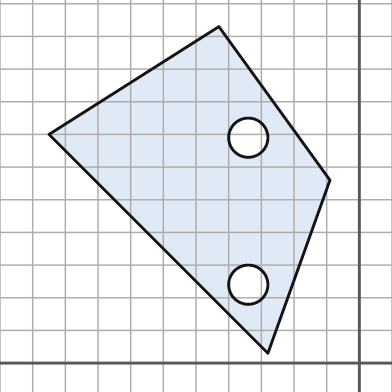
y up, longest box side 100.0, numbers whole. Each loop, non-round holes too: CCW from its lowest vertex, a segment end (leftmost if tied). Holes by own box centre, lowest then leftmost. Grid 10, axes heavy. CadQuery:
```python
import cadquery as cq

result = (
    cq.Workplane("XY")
    .moveTo(-28.0, 3.0)
    .lineTo(-9.0, 56.0)
    .lineTo(-43.0, 103.0)
    .lineTo(-95.0, 70.0)
    .close()
    .moveTo(-34.0, 24.0)
    .circle(6.0)
    .moveTo(-34.0, 69.0)
    .circle(6.0)
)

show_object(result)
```